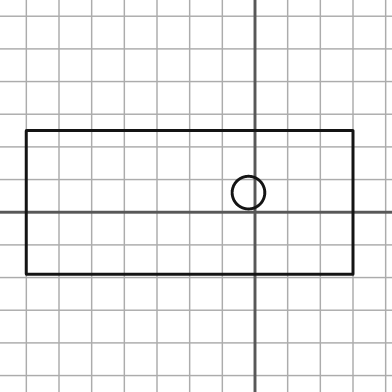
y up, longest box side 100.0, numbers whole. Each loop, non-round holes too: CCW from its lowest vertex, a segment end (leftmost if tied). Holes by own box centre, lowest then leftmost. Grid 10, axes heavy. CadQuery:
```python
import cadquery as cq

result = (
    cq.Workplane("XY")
    .moveTo(-70.0, -19.0)
    .lineTo(30.0, -19.0)
    .lineTo(30.0, 25.0)
    .lineTo(-70.0, 25.0)
    .close()
    .moveTo(-2.0, 6.0)
    .circle(5.0)
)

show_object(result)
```